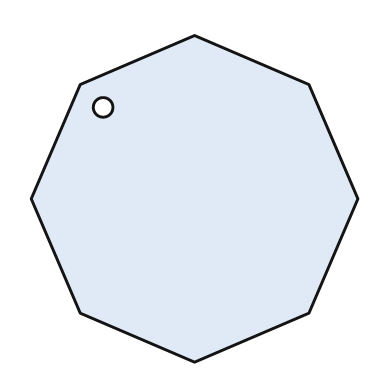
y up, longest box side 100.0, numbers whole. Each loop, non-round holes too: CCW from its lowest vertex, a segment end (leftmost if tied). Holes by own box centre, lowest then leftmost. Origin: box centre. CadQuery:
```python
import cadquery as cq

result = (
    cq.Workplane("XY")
    .moveTo(0.0, -50.0)
    .lineTo(35.0, -35.0)
    .lineTo(50.0, 0.0)
    .lineTo(35.0, 35.0)
    .lineTo(0.0, 50.0)
    .lineTo(-35.0, 35.0)
    .lineTo(-50.0, 0.0)
    .lineTo(-35.0, -35.0)
    .close()
    .moveTo(-28.0, 28.0)
    .circle(3.0)
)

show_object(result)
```